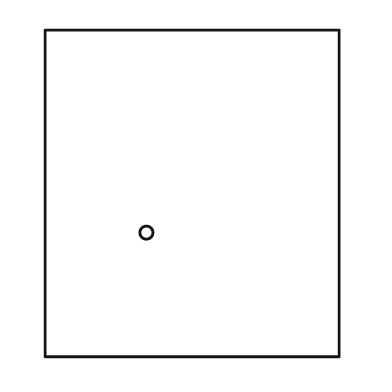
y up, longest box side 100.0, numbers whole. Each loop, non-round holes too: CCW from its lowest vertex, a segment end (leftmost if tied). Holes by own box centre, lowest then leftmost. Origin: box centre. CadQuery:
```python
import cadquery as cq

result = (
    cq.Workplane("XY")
    .moveTo(-45.0, -50.0)
    .lineTo(45.0, -50.0)
    .lineTo(45.0, 50.0)
    .lineTo(-45.0, 50.0)
    .close()
    .moveTo(-14.0, -12.0)
    .circle(2.0)
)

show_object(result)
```